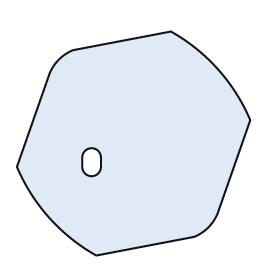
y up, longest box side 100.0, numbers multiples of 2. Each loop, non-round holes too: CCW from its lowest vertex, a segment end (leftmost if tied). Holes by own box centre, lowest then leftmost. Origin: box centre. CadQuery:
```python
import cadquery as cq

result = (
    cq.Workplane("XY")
    .moveTo(-16.0, -48.0)
    .lineTo(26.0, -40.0)
    .threePointArc((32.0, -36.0), (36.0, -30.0))
    .lineTo(50.0, 10.0)
    .threePointArc((36.0, 32.0), (16.0, 48.0))
    .lineTo(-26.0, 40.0)
    .threePointArc((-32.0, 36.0), (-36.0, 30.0))
    .lineTo(-50.0, -10.0)
    .threePointArc((-36.0, -32.0), (-16.0, -48.0))
    .close()
    .moveTo(-22.0, -10.0)
    .threePointArc((-18.0, -14.0), (-14.0, -10.0))
    .lineTo(-14.0, -6.0)
    .threePointArc((-18.0, -2.0), (-22.0, -6.0))
    .close()
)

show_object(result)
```